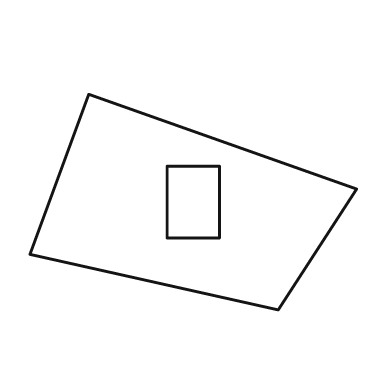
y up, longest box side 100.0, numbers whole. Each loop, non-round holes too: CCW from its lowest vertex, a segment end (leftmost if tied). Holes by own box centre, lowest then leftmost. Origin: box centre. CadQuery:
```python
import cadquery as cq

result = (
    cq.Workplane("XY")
    .moveTo(26.0, -33.0)
    .lineTo(50.0, 4.0)
    .lineTo(-32.0, 33.0)
    .lineTo(-50.0, -16.0)
    .close()
    .moveTo(-8.0, -11.0)
    .lineTo(8.0, -11.0)
    .lineTo(8.0, 11.0)
    .lineTo(-8.0, 11.0)
    .close()
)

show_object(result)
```